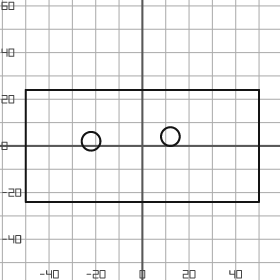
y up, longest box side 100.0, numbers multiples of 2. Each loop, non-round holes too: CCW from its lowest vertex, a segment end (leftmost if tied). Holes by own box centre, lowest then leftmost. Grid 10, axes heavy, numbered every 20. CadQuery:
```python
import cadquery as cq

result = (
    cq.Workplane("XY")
    .moveTo(-50.0, -24.0)
    .lineTo(50.0, -24.0)
    .lineTo(50.0, 24.0)
    .lineTo(-50.0, 24.0)
    .close()
    .moveTo(-22.0, 2.0)
    .circle(4.0)
    .moveTo(12.0, 4.0)
    .circle(4.0)
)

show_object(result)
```